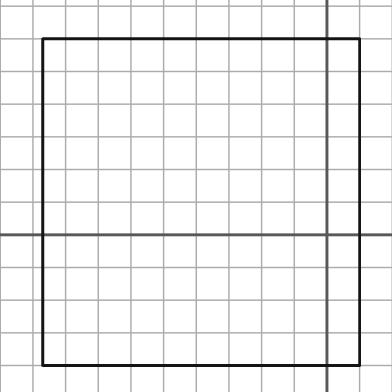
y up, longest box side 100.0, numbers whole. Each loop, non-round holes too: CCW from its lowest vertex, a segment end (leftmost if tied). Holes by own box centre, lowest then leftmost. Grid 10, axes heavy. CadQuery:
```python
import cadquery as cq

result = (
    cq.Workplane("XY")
    .moveTo(-87.0, -40.0)
    .lineTo(10.0, -40.0)
    .lineTo(10.0, 60.0)
    .lineTo(-87.0, 60.0)
    .close()
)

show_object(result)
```